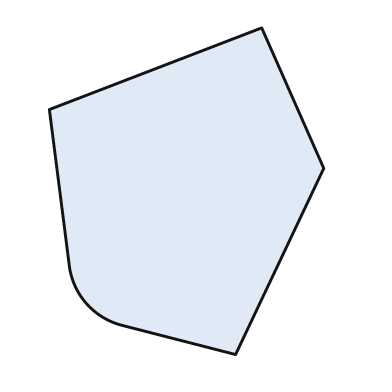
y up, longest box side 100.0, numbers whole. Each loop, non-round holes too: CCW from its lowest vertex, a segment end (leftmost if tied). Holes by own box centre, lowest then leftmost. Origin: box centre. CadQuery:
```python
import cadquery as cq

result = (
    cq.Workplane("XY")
    .moveTo(15.0, -50.0)
    .lineTo(42.0, 7.0)
    .lineTo(23.0, 50.0)
    .lineTo(-42.0, 25.0)
    .lineTo(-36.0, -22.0)
    .threePointArc((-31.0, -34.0), (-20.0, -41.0))
    .close()
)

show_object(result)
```